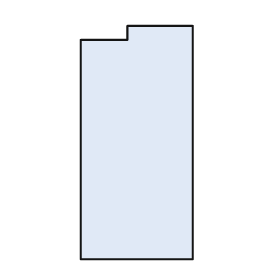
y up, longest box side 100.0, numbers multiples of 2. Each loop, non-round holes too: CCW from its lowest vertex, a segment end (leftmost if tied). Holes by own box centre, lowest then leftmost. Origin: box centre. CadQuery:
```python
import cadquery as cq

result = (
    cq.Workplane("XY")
    .moveTo(-24.0, -50.0)
    .lineTo(24.0, -50.0)
    .lineTo(24.0, 50.0)
    .lineTo(-4.0, 50.0)
    .lineTo(-4.0, 44.0)
    .lineTo(-24.0, 44.0)
    .close()
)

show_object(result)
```